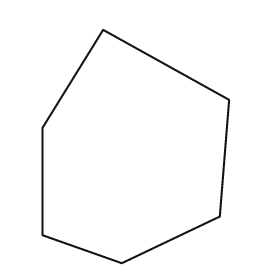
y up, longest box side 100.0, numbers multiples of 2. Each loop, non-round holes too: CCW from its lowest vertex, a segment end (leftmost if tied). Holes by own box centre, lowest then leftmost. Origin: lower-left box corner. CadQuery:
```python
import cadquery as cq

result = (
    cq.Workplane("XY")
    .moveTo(34.0, 0.0)
    .lineTo(76.0, 20.0)
    .lineTo(80.0, 70.0)
    .lineTo(26.0, 100.0)
    .lineTo(0.0, 58.0)
    .lineTo(0.0, 12.0)
    .close()
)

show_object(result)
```